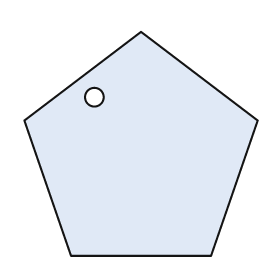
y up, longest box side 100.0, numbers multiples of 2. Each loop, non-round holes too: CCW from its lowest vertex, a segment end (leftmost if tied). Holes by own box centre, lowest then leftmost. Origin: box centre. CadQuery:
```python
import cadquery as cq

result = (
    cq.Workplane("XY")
    .moveTo(-30.0, -48.0)
    .lineTo(30.0, -48.0)
    .lineTo(50.0, 10.0)
    .lineTo(0.0, 48.0)
    .lineTo(-50.0, 10.0)
    .close()
    .moveTo(-20.0, 20.0)
    .circle(4.0)
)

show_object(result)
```